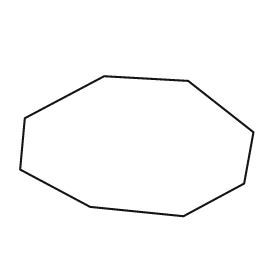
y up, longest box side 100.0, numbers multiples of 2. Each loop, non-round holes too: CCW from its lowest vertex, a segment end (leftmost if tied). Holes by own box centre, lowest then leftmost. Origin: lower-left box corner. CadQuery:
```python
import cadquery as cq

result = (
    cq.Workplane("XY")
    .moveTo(70.0, 0.0)
    .lineTo(96.0, 14.0)
    .lineTo(100.0, 36.0)
    .lineTo(72.0, 58.0)
    .lineTo(36.0, 60.0)
    .lineTo(2.0, 42.0)
    .lineTo(0.0, 20.0)
    .lineTo(30.0, 4.0)
    .close()
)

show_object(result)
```